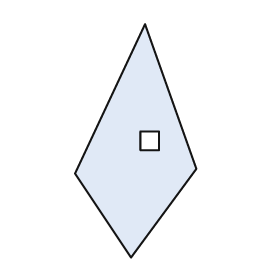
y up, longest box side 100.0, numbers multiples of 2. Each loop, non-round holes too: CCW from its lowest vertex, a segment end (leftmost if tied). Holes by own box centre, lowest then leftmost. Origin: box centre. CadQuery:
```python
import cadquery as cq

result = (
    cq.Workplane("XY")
    .moveTo(-2.0, -50.0)
    .lineTo(26.0, -12.0)
    .lineTo(4.0, 50.0)
    .lineTo(-26.0, -14.0)
    .close()
    .moveTo(2.0, -4.0)
    .lineTo(10.0, -4.0)
    .lineTo(10.0, 4.0)
    .lineTo(2.0, 4.0)
    .close()
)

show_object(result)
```